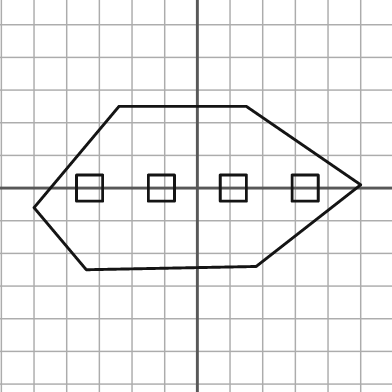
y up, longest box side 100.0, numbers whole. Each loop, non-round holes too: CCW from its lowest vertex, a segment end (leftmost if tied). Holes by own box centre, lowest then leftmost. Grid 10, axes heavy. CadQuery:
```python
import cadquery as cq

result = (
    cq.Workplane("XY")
    .moveTo(-34.0, -25.0)
    .lineTo(18.0, -24.0)
    .lineTo(50.0, 1.0)
    .lineTo(15.0, 25.0)
    .lineTo(-24.0, 25.0)
    .lineTo(-50.0, -6.0)
    .close()
    .moveTo(-37.0, -4.0)
    .lineTo(-29.0, -4.0)
    .lineTo(-29.0, 4.0)
    .lineTo(-37.0, 4.0)
    .close()
    .moveTo(-15.0, -4.0)
    .lineTo(-7.0, -4.0)
    .lineTo(-7.0, 4.0)
    .lineTo(-15.0, 4.0)
    .close()
    .moveTo(7.0, -4.0)
    .lineTo(15.0, -4.0)
    .lineTo(15.0, 4.0)
    .lineTo(7.0, 4.0)
    .close()
    .moveTo(29.0, -4.0)
    .lineTo(37.0, -4.0)
    .lineTo(37.0, 4.0)
    .lineTo(29.0, 4.0)
    .close()
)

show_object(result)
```